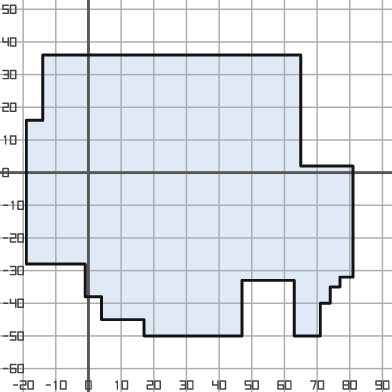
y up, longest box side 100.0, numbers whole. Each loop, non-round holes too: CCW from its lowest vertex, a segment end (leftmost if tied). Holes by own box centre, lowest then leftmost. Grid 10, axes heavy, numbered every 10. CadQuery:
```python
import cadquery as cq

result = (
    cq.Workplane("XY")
    .moveTo(17.0, -50.0)
    .lineTo(47.0, -50.0)
    .lineTo(47.0, -33.0)
    .lineTo(63.0, -33.0)
    .lineTo(63.0, -50.0)
    .lineTo(71.0, -50.0)
    .lineTo(71.0, -40.0)
    .lineTo(74.0, -40.0)
    .lineTo(74.0, -35.0)
    .lineTo(77.0, -35.0)
    .lineTo(77.0, -32.0)
    .lineTo(81.0, -32.0)
    .lineTo(81.0, 2.0)
    .lineTo(65.0, 2.0)
    .lineTo(65.0, 36.0)
    .lineTo(-14.0, 36.0)
    .lineTo(-14.0, 16.0)
    .lineTo(-19.0, 16.0)
    .lineTo(-19.0, -28.0)
    .lineTo(-1.0, -28.0)
    .lineTo(-1.0, -38.0)
    .lineTo(4.0, -38.0)
    .lineTo(4.0, -45.0)
    .lineTo(17.0, -45.0)
    .close()
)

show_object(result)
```